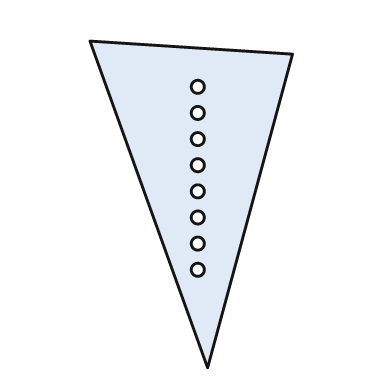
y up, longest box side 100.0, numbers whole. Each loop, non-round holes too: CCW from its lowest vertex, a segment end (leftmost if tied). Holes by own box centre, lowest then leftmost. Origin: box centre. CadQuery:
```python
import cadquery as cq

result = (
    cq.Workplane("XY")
    .moveTo(5.0, -50.0)
    .lineTo(31.0, 46.0)
    .lineTo(-31.0, 50.0)
    .close()
    .moveTo(2.0, -20.0)
    .circle(2.0)
    .moveTo(2.0, -12.0)
    .circle(2.0)
    .moveTo(2.0, -4.0)
    .circle(2.0)
    .moveTo(2.0, 4.0)
    .circle(2.0)
    .moveTo(2.0, 12.0)
    .circle(2.0)
    .moveTo(2.0, 20.0)
    .circle(2.0)
    .moveTo(2.0, 28.0)
    .circle(2.0)
    .moveTo(2.0, 36.0)
    .circle(2.0)
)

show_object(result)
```